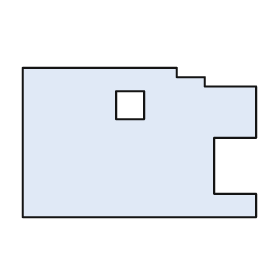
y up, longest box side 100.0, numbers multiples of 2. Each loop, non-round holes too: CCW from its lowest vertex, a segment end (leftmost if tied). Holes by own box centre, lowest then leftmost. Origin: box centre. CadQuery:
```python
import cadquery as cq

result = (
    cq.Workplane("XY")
    .moveTo(-50.0, -32.0)
    .lineTo(50.0, -32.0)
    .lineTo(50.0, -22.0)
    .lineTo(32.0, -22.0)
    .lineTo(32.0, 2.0)
    .lineTo(50.0, 2.0)
    .lineTo(50.0, 24.0)
    .lineTo(28.0, 24.0)
    .lineTo(28.0, 28.0)
    .lineTo(16.0, 28.0)
    .lineTo(16.0, 32.0)
    .lineTo(-50.0, 32.0)
    .close()
    .moveTo(-10.0, 10.0)
    .lineTo(2.0, 10.0)
    .lineTo(2.0, 22.0)
    .lineTo(-10.0, 22.0)
    .close()
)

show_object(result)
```